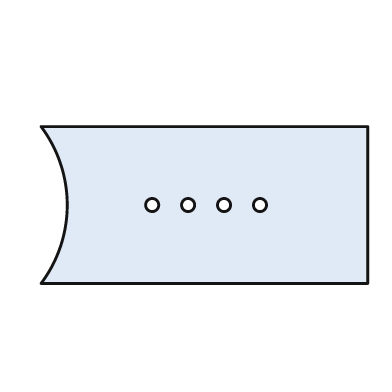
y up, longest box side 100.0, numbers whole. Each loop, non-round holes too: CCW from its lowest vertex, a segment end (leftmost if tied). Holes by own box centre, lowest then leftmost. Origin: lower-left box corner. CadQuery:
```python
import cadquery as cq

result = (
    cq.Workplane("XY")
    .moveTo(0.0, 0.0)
    .lineTo(100.0, 0.0)
    .lineTo(100.0, 48.0)
    .lineTo(0.0, 48.0)
    .threePointArc((8.0, 24.0), (0.0, 0.0))
    .close()
    .moveTo(34.0, 24.0)
    .circle(2.0)
    .moveTo(45.0, 24.0)
    .circle(2.0)
    .moveTo(56.0, 24.0)
    .circle(2.0)
    .moveTo(67.0, 24.0)
    .circle(2.0)
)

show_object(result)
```